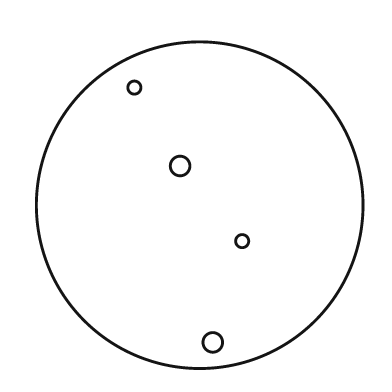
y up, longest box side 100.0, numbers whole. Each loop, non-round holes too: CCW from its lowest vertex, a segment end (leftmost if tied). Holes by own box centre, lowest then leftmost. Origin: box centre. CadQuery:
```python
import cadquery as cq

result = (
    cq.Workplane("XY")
    .moveTo(0.0, 0.0)
    .circle(50.0)
    .moveTo(4.0, -42.0)
    .circle(3.0)
    .moveTo(13.0, -11.0)
    .circle(2.0)
    .moveTo(-6.0, 12.0)
    .circle(3.0)
    .moveTo(-20.0, 36.0)
    .circle(2.0)
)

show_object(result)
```